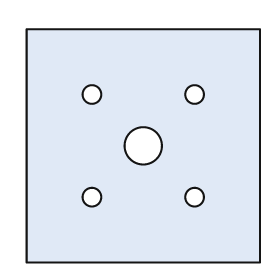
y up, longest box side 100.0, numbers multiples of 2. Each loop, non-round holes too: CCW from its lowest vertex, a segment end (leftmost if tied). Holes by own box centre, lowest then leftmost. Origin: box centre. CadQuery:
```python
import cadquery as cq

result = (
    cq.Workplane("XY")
    .moveTo(-50.0, -50.0)
    .lineTo(50.0, -50.0)
    .lineTo(50.0, 50.0)
    .lineTo(-50.0, 50.0)
    .close()
    .moveTo(-22.0, -22.0)
    .circle(4.0)
    .moveTo(22.0, -22.0)
    .circle(4.0)
    .moveTo(0.0, 0.0)
    .circle(8.0)
    .moveTo(-22.0, 22.0)
    .circle(4.0)
    .moveTo(22.0, 22.0)
    .circle(4.0)
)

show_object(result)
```